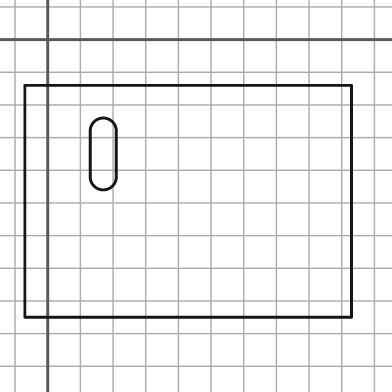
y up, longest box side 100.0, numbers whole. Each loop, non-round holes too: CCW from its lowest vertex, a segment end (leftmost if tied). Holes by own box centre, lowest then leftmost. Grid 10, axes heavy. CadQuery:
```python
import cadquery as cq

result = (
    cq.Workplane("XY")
    .moveTo(-7.0, -85.0)
    .lineTo(93.0, -85.0)
    .lineTo(93.0, -14.0)
    .lineTo(-7.0, -14.0)
    .close()
    .moveTo(13.0, -42.0)
    .threePointArc((17.0, -46.0), (21.0, -42.0))
    .lineTo(21.0, -28.0)
    .threePointArc((17.0, -24.0), (13.0, -28.0))
    .close()
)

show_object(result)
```